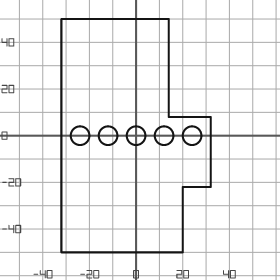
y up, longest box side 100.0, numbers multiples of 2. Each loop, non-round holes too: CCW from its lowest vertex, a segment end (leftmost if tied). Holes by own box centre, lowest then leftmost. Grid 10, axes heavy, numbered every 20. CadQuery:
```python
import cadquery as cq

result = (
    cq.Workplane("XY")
    .moveTo(-32.0, -50.0)
    .lineTo(20.0, -50.0)
    .lineTo(20.0, -22.0)
    .lineTo(32.0, -22.0)
    .lineTo(32.0, 8.0)
    .lineTo(14.0, 8.0)
    .lineTo(14.0, 50.0)
    .lineTo(-32.0, 50.0)
    .close()
    .moveTo(-24.0, 0.0)
    .circle(4.0)
    .moveTo(-12.0, 0.0)
    .circle(4.0)
    .moveTo(0.0, 0.0)
    .circle(4.0)
    .moveTo(12.0, 0.0)
    .circle(4.0)
    .moveTo(24.0, 0.0)
    .circle(4.0)
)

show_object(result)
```